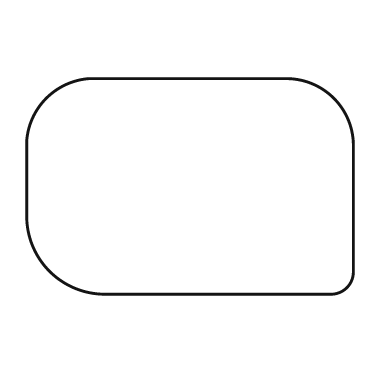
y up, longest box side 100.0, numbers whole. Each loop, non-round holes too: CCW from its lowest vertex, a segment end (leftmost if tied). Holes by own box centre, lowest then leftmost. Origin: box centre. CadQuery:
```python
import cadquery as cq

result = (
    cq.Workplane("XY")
    .moveTo(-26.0, -33.0)
    .lineTo(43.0, -33.0)
    .threePointArc((48.0, -31.0), (50.0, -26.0))
    .lineTo(50.0, 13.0)
    .threePointArc((44.0, 27.0), (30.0, 33.0))
    .lineTo(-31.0, 33.0)
    .threePointArc((-44.0, 27.0), (-50.0, 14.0))
    .lineTo(-50.0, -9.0)
    .threePointArc((-43.0, -26.0), (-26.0, -33.0))
    .close()
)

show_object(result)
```